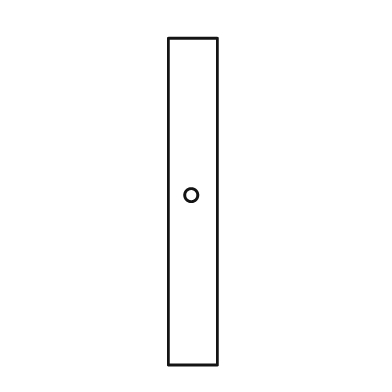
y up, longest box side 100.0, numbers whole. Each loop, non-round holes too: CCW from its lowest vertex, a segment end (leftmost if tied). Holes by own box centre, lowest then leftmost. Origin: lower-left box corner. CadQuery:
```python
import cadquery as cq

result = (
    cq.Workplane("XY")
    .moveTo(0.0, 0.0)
    .lineTo(15.0, 0.0)
    .lineTo(15.0, 100.0)
    .lineTo(0.0, 100.0)
    .close()
    .moveTo(7.0, 52.0)
    .circle(2.0)
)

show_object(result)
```